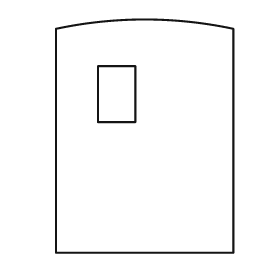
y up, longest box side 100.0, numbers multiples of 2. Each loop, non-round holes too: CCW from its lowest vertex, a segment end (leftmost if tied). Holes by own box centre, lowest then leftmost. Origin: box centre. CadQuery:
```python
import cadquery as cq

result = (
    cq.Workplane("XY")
    .moveTo(-38.0, -50.0)
    .lineTo(38.0, -50.0)
    .lineTo(38.0, 46.0)
    .threePointArc((0.0, 50.0), (-38.0, 46.0))
    .close()
    .moveTo(-20.0, 6.0)
    .lineTo(-4.0, 6.0)
    .lineTo(-4.0, 30.0)
    .lineTo(-20.0, 30.0)
    .close()
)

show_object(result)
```